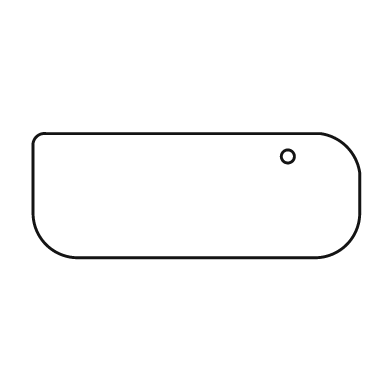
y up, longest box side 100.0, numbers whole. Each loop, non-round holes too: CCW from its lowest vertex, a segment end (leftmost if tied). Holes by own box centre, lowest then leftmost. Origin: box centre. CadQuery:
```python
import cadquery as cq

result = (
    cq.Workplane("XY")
    .moveTo(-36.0, -19.0)
    .lineTo(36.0, -19.0)
    .threePointArc((46.0, -15.0), (50.0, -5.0))
    .lineTo(50.0, 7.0)
    .threePointArc((46.0, 15.0), (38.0, 19.0))
    .lineTo(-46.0, 19.0)
    .threePointArc((-49.0, 18.0), (-50.0, 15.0))
    .lineTo(-50.0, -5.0)
    .threePointArc((-46.0, -15.0), (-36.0, -19.0))
    .close()
    .moveTo(28.0, 12.0)
    .circle(2.0)
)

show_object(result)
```